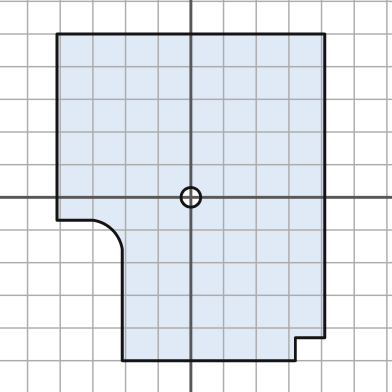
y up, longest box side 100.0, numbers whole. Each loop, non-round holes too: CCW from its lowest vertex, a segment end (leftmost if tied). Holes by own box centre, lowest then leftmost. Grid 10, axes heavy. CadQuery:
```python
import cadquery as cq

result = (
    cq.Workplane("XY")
    .moveTo(-21.0, -50.0)
    .lineTo(32.0, -50.0)
    .lineTo(32.0, -43.0)
    .lineTo(41.0, -43.0)
    .lineTo(41.0, 50.0)
    .lineTo(-41.0, 50.0)
    .lineTo(-41.0, -7.0)
    .lineTo(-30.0, -7.0)
    .threePointArc((-24.0, -10.0), (-21.0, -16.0))
    .close()
    .moveTo(0.0, 0.0)
    .circle(3.0)
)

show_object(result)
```